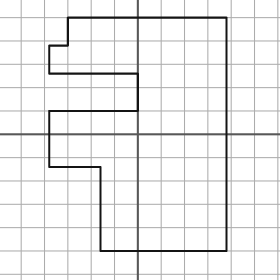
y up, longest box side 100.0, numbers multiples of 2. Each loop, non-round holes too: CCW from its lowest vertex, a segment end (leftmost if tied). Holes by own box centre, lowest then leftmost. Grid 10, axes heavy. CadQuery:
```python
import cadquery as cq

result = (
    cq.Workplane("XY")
    .moveTo(-16.0, -50.0)
    .lineTo(38.0, -50.0)
    .lineTo(38.0, 50.0)
    .lineTo(-30.0, 50.0)
    .lineTo(-30.0, 38.0)
    .lineTo(-38.0, 38.0)
    .lineTo(-38.0, 26.0)
    .lineTo(0.0, 26.0)
    .lineTo(0.0, 10.0)
    .lineTo(-38.0, 10.0)
    .lineTo(-38.0, -14.0)
    .lineTo(-16.0, -14.0)
    .close()
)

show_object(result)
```